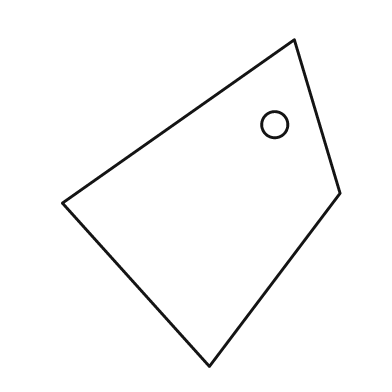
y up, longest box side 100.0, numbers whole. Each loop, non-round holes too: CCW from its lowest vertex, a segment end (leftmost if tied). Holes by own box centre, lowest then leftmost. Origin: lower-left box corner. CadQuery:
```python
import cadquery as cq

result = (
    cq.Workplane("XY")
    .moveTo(45.0, 0.0)
    .lineTo(85.0, 53.0)
    .lineTo(71.0, 100.0)
    .lineTo(0.0, 50.0)
    .close()
    .moveTo(65.0, 74.0)
    .circle(4.0)
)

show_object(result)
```